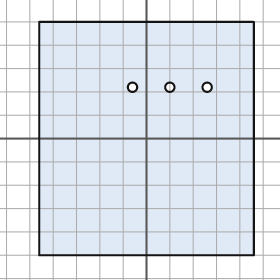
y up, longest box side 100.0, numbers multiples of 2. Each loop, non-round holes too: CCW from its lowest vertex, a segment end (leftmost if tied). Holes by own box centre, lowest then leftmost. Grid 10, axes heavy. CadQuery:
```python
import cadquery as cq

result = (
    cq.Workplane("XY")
    .moveTo(-46.0, -50.0)
    .lineTo(46.0, -50.0)
    .lineTo(46.0, 50.0)
    .lineTo(-46.0, 50.0)
    .close()
    .moveTo(-6.0, 22.0)
    .circle(2.0)
    .moveTo(10.0, 22.0)
    .circle(2.0)
    .moveTo(26.0, 22.0)
    .circle(2.0)
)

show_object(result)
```